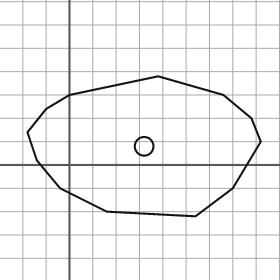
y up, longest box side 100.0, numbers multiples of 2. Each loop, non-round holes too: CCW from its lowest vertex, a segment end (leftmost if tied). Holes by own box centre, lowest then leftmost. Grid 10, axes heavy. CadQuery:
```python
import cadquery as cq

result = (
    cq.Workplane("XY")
    .moveTo(54.0, -22.0)
    .lineTo(70.0, -10.0)
    .lineTo(82.0, 10.0)
    .lineTo(78.0, 20.0)
    .lineTo(66.0, 30.0)
    .lineTo(38.0, 38.0)
    .lineTo(0.0, 30.0)
    .lineTo(-10.0, 24.0)
    .lineTo(-18.0, 14.0)
    .lineTo(-14.0, 2.0)
    .lineTo(-4.0, -10.0)
    .lineTo(16.0, -20.0)
    .close()
    .moveTo(32.0, 8.0)
    .circle(4.0)
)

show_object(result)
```